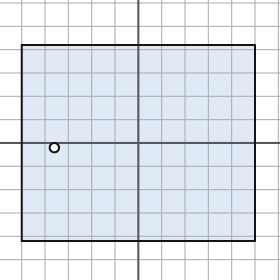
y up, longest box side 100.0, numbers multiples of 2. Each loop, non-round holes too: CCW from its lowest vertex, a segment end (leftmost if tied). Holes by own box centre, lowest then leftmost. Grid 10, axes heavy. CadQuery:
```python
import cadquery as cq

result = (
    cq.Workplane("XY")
    .moveTo(-50.0, -42.0)
    .lineTo(50.0, -42.0)
    .lineTo(50.0, 42.0)
    .lineTo(-50.0, 42.0)
    .close()
    .moveTo(-36.0, -2.0)
    .circle(2.0)
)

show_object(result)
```